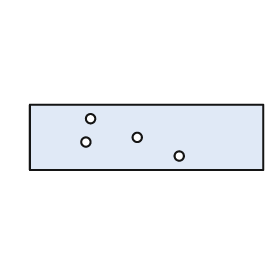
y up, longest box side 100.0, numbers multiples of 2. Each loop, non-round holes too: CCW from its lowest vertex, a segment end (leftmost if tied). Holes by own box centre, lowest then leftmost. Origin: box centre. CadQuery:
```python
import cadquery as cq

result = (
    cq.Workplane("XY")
    .moveTo(-50.0, -14.0)
    .lineTo(50.0, -14.0)
    .lineTo(50.0, 14.0)
    .lineTo(-50.0, 14.0)
    .close()
    .moveTo(14.0, -8.0)
    .circle(2.0)
    .moveTo(-26.0, -2.0)
    .circle(2.0)
    .moveTo(-4.0, 0.0)
    .circle(2.0)
    .moveTo(-24.0, 8.0)
    .circle(2.0)
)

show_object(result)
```